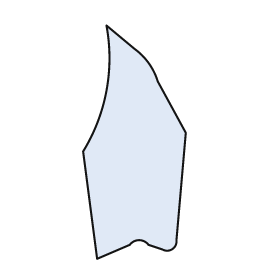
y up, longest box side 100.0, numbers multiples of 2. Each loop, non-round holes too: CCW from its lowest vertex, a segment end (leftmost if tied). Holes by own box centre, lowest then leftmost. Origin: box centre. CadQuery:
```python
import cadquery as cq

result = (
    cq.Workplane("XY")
    .moveTo(-16.0, -50.0)
    .lineTo(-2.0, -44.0)
    .threePointArc((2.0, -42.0), (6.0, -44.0))
    .lineTo(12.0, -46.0)
    .threePointArc((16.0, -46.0), (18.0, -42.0))
    .lineTo(22.0, 4.0)
    .lineTo(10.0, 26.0)
    .threePointArc((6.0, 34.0), (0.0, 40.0))
    .lineTo(-12.0, 50.0)
    .threePointArc((-12.0, 22.0), (-22.0, -4.0))
    .close()
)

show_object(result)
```